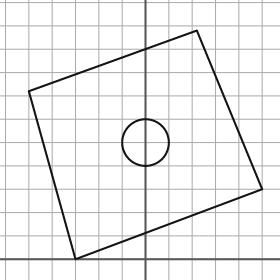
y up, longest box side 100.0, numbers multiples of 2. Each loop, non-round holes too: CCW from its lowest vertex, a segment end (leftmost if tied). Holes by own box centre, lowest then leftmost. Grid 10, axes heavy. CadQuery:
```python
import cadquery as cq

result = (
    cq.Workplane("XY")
    .moveTo(-30.0, 0.0)
    .lineTo(50.0, 30.0)
    .lineTo(22.0, 98.0)
    .lineTo(-50.0, 72.0)
    .close()
    .moveTo(0.0, 50.0)
    .circle(10.0)
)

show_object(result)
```